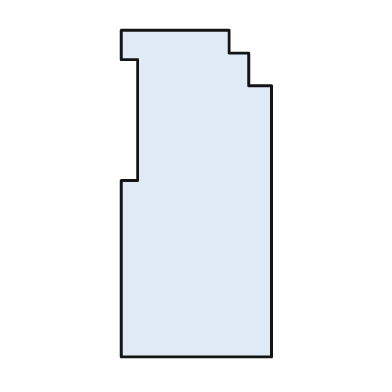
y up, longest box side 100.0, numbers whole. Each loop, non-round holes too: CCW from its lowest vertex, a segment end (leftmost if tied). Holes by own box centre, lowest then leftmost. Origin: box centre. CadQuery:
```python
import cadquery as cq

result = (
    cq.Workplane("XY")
    .moveTo(-23.0, -50.0)
    .lineTo(23.0, -50.0)
    .lineTo(23.0, 33.0)
    .lineTo(16.0, 33.0)
    .lineTo(16.0, 43.0)
    .lineTo(10.0, 43.0)
    .lineTo(10.0, 50.0)
    .lineTo(-23.0, 50.0)
    .lineTo(-23.0, 41.0)
    .lineTo(-18.0, 41.0)
    .lineTo(-18.0, 4.0)
    .lineTo(-23.0, 4.0)
    .close()
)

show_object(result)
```